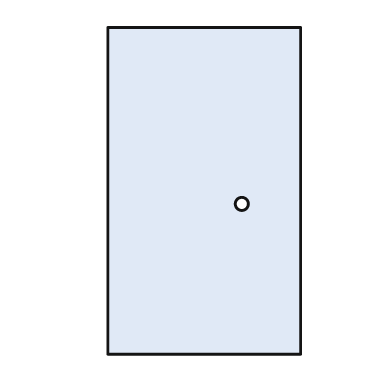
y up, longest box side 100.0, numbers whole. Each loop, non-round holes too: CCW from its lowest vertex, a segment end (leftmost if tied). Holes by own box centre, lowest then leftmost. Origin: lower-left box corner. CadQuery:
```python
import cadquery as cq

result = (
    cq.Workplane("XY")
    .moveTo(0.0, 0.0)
    .lineTo(59.0, 0.0)
    .lineTo(59.0, 100.0)
    .lineTo(0.0, 100.0)
    .close()
    .moveTo(41.0, 46.0)
    .circle(2.0)
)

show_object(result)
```